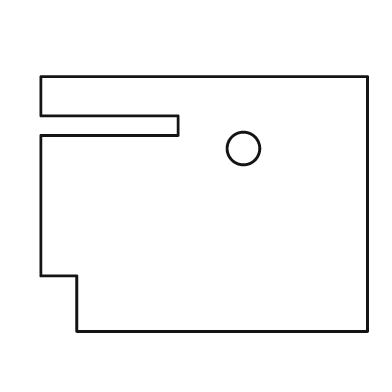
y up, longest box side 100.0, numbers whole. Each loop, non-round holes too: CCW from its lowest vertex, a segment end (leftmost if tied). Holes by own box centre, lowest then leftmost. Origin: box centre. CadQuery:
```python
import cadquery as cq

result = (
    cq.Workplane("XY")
    .moveTo(-39.0, -39.0)
    .lineTo(50.0, -39.0)
    .lineTo(50.0, 39.0)
    .lineTo(-50.0, 39.0)
    .lineTo(-50.0, 27.0)
    .lineTo(-8.0, 27.0)
    .lineTo(-8.0, 21.0)
    .lineTo(-50.0, 21.0)
    .lineTo(-50.0, -22.0)
    .lineTo(-39.0, -22.0)
    .close()
    .moveTo(12.0, 17.0)
    .circle(5.0)
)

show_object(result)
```